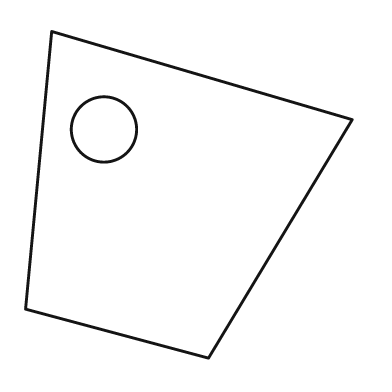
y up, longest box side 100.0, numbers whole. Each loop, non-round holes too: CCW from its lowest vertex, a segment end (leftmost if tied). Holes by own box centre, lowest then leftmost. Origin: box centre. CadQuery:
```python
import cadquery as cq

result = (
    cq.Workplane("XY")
    .moveTo(6.0, -50.0)
    .lineTo(50.0, 23.0)
    .lineTo(-42.0, 50.0)
    .lineTo(-50.0, -35.0)
    .close()
    .moveTo(-26.0, 20.0)
    .circle(10.0)
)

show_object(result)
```